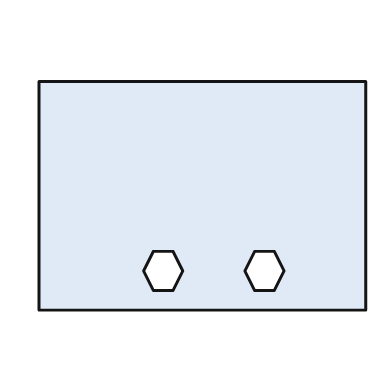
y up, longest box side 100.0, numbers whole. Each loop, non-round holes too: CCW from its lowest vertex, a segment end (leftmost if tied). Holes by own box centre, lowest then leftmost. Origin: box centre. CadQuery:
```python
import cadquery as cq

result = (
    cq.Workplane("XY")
    .moveTo(-50.0, -35.0)
    .lineTo(50.0, -35.0)
    .lineTo(50.0, 35.0)
    .lineTo(-50.0, 35.0)
    .close()
    .moveTo(-15.0, -29.0)
    .lineTo(-9.0, -29.0)
    .lineTo(-6.0, -23.0)
    .lineTo(-9.0, -17.0)
    .lineTo(-15.0, -17.0)
    .lineTo(-18.0, -23.0)
    .close()
    .moveTo(16.0, -29.0)
    .lineTo(22.0, -29.0)
    .lineTo(25.0, -23.0)
    .lineTo(22.0, -17.0)
    .lineTo(16.0, -17.0)
    .lineTo(13.0, -23.0)
    .close()
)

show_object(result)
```